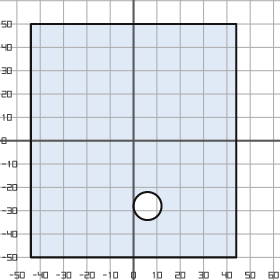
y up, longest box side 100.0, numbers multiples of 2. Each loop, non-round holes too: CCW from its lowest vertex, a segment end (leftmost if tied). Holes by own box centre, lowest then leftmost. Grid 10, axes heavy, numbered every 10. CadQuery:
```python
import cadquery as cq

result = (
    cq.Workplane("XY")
    .moveTo(-44.0, -50.0)
    .lineTo(44.0, -50.0)
    .lineTo(44.0, 50.0)
    .lineTo(-44.0, 50.0)
    .close()
    .moveTo(6.0, -28.0)
    .circle(6.0)
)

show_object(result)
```